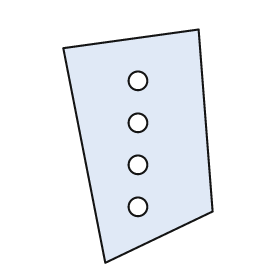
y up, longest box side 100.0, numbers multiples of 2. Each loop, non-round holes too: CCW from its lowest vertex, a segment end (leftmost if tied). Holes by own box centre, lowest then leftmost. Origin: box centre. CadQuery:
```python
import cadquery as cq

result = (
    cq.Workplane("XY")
    .moveTo(-14.0, -50.0)
    .lineTo(32.0, -28.0)
    .lineTo(26.0, 50.0)
    .lineTo(-32.0, 42.0)
    .close()
    .moveTo(0.0, -26.0)
    .circle(4.0)
    .moveTo(0.0, -8.0)
    .circle(4.0)
    .moveTo(0.0, 10.0)
    .circle(4.0)
    .moveTo(0.0, 28.0)
    .circle(4.0)
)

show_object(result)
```